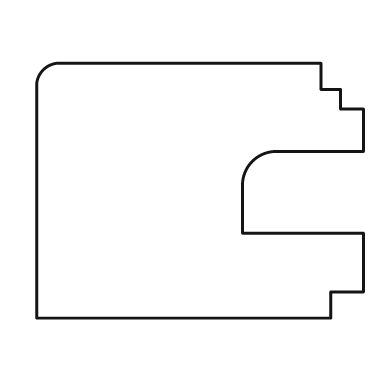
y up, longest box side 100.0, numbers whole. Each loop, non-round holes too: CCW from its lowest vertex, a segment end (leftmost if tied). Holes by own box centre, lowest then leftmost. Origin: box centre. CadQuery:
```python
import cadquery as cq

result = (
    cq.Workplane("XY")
    .moveTo(-50.0, -39.0)
    .lineTo(40.0, -39.0)
    .lineTo(40.0, -31.0)
    .lineTo(50.0, -31.0)
    .lineTo(50.0, -13.0)
    .lineTo(13.0, -13.0)
    .lineTo(13.0, 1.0)
    .threePointArc((16.0, 9.0), (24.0, 12.0))
    .lineTo(50.0, 12.0)
    .lineTo(50.0, 25.0)
    .lineTo(43.0, 25.0)
    .lineTo(43.0, 31.0)
    .lineTo(37.0, 31.0)
    .lineTo(37.0, 39.0)
    .lineTo(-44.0, 39.0)
    .threePointArc((-48.0, 37.0), (-50.0, 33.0))
    .close()
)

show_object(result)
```